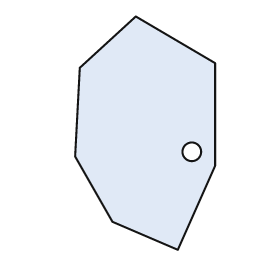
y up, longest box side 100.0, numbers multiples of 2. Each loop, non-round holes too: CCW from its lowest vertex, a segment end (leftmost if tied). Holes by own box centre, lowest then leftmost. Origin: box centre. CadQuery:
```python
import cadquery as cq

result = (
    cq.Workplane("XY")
    .moveTo(14.0, -50.0)
    .lineTo(30.0, -14.0)
    .lineTo(30.0, 30.0)
    .lineTo(-4.0, 50.0)
    .lineTo(-28.0, 28.0)
    .lineTo(-30.0, -10.0)
    .lineTo(-14.0, -38.0)
    .close()
    .moveTo(20.0, -8.0)
    .circle(4.0)
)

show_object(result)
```